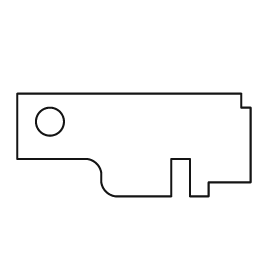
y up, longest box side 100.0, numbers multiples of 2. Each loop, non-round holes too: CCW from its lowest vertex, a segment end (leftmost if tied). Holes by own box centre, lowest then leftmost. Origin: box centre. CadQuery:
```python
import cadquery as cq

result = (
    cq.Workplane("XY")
    .moveTo(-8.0, -22.0)
    .lineTo(16.0, -22.0)
    .lineTo(16.0, -6.0)
    .lineTo(24.0, -6.0)
    .lineTo(24.0, -22.0)
    .lineTo(32.0, -22.0)
    .lineTo(32.0, -16.0)
    .lineTo(50.0, -16.0)
    .lineTo(50.0, 16.0)
    .lineTo(46.0, 16.0)
    .lineTo(46.0, 22.0)
    .lineTo(-50.0, 22.0)
    .lineTo(-50.0, -6.0)
    .lineTo(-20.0, -6.0)
    .threePointArc((-16.0, -8.0), (-14.0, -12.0))
    .lineTo(-14.0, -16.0)
    .threePointArc((-12.0, -20.0), (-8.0, -22.0))
    .close()
    .moveTo(-36.0, 10.0)
    .circle(6.0)
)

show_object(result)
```